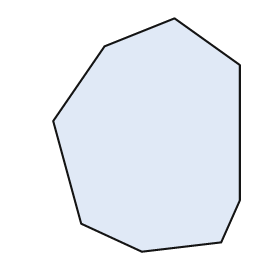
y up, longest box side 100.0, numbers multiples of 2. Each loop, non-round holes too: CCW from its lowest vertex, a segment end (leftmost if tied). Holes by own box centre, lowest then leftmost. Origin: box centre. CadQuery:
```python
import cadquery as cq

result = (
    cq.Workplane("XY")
    .moveTo(-2.0, -50.0)
    .lineTo(32.0, -46.0)
    .lineTo(40.0, -28.0)
    .lineTo(40.0, 30.0)
    .lineTo(12.0, 50.0)
    .lineTo(-18.0, 38.0)
    .lineTo(-40.0, 6.0)
    .lineTo(-28.0, -38.0)
    .close()
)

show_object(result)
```